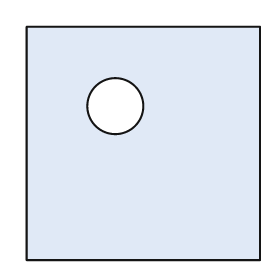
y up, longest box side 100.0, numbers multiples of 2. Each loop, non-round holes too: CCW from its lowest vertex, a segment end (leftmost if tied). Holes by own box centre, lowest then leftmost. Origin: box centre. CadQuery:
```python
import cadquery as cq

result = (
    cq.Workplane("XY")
    .moveTo(-50.0, -50.0)
    .lineTo(50.0, -50.0)
    .lineTo(50.0, 50.0)
    .lineTo(-50.0, 50.0)
    .close()
    .moveTo(-12.0, 16.0)
    .circle(12.0)
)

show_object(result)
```